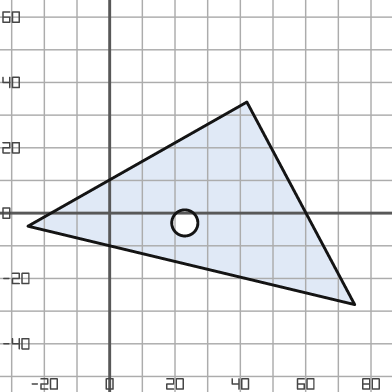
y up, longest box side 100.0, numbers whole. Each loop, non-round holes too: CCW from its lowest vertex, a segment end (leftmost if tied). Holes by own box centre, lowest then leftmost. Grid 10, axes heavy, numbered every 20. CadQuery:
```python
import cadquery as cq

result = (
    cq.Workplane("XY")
    .moveTo(75.0, -28.0)
    .lineTo(42.0, 34.0)
    .lineTo(-25.0, -4.0)
    .close()
    .moveTo(23.0, -3.0)
    .circle(4.0)
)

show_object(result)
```